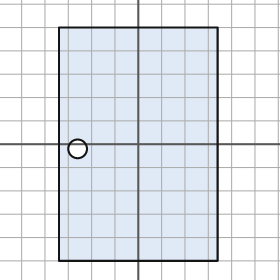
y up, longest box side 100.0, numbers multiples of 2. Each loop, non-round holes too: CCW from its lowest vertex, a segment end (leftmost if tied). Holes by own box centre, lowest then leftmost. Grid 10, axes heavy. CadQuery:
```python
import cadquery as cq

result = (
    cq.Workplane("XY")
    .moveTo(-34.0, -50.0)
    .lineTo(34.0, -50.0)
    .lineTo(34.0, 50.0)
    .lineTo(-34.0, 50.0)
    .close()
    .moveTo(-26.0, -2.0)
    .circle(4.0)
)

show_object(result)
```